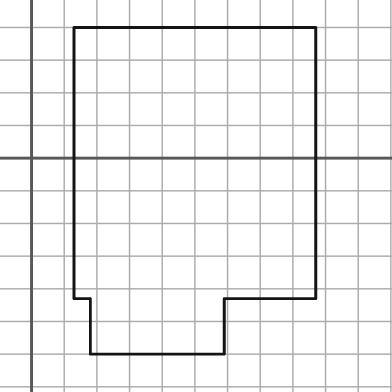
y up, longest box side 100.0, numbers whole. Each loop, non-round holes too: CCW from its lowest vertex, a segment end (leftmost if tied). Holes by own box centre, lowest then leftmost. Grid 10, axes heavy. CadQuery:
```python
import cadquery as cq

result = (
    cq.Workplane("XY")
    .moveTo(18.0, -60.0)
    .lineTo(59.0, -60.0)
    .lineTo(59.0, -43.0)
    .lineTo(87.0, -43.0)
    .lineTo(87.0, 40.0)
    .lineTo(13.0, 40.0)
    .lineTo(13.0, -43.0)
    .lineTo(18.0, -43.0)
    .close()
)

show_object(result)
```